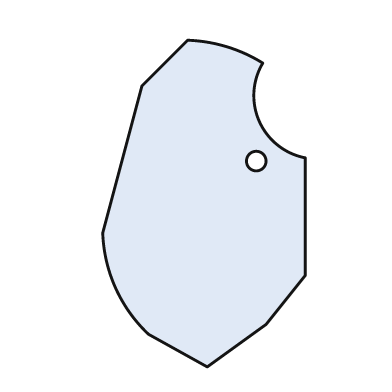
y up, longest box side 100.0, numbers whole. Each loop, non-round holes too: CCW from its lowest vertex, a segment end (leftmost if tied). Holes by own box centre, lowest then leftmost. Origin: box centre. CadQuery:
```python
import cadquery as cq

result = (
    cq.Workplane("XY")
    .moveTo(1.0, -50.0)
    .lineTo(19.0, -37.0)
    .lineTo(31.0, -22.0)
    .lineTo(31.0, 14.0)
    .threePointArc((17.0, 25.0), (18.0, 43.0))
    .threePointArc((7.0, 48.0), (-5.0, 50.0))
    .lineTo(-19.0, 36.0)
    .lineTo(-31.0, -9.0)
    .threePointArc((-27.0, -26.0), (-17.0, -40.0))
    .close()
    .moveTo(16.0, 13.0)
    .circle(3.0)
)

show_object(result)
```